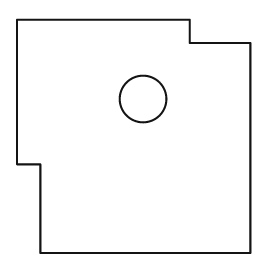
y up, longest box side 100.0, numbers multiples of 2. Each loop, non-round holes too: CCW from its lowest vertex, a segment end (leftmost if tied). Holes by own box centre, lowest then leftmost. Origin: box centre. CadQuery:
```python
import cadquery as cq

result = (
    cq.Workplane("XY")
    .moveTo(-40.0, -50.0)
    .lineTo(50.0, -50.0)
    .lineTo(50.0, 40.0)
    .lineTo(24.0, 40.0)
    .lineTo(24.0, 50.0)
    .lineTo(-50.0, 50.0)
    .lineTo(-50.0, -12.0)
    .lineTo(-40.0, -12.0)
    .close()
    .moveTo(4.0, 16.0)
    .circle(10.0)
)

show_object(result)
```